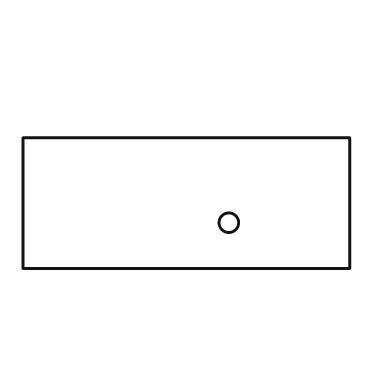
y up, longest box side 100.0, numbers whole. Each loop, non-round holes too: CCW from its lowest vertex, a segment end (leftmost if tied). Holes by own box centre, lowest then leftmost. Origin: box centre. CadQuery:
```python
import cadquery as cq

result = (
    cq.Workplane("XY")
    .moveTo(-50.0, -20.0)
    .lineTo(50.0, -20.0)
    .lineTo(50.0, 20.0)
    .lineTo(-50.0, 20.0)
    .close()
    .moveTo(13.0, -6.0)
    .circle(3.0)
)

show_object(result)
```